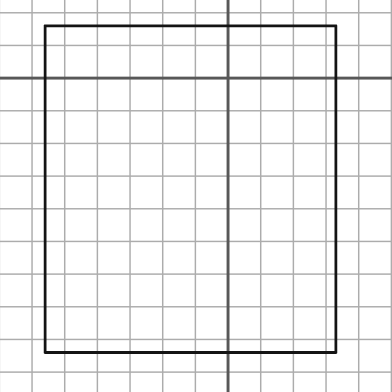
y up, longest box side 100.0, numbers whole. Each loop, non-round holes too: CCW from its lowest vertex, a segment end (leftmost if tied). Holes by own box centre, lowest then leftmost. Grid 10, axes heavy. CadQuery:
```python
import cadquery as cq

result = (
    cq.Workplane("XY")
    .moveTo(-56.0, -84.0)
    .lineTo(33.0, -84.0)
    .lineTo(33.0, 16.0)
    .lineTo(-56.0, 16.0)
    .close()
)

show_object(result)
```